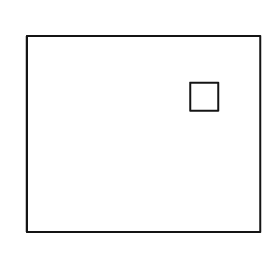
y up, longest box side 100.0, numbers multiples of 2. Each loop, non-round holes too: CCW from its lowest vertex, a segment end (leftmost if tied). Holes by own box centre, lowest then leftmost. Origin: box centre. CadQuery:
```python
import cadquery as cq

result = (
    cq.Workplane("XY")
    .moveTo(-50.0, -42.0)
    .lineTo(50.0, -42.0)
    .lineTo(50.0, 42.0)
    .lineTo(-50.0, 42.0)
    .close()
    .moveTo(20.0, 10.0)
    .lineTo(32.0, 10.0)
    .lineTo(32.0, 22.0)
    .lineTo(20.0, 22.0)
    .close()
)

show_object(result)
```